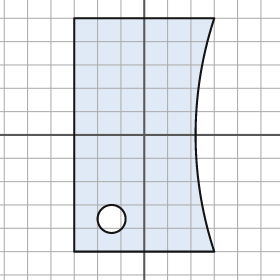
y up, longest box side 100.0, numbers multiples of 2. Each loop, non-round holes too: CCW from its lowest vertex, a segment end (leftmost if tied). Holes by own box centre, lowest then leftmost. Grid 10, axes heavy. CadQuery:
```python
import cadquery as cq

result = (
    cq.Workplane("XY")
    .moveTo(-30.0, -50.0)
    .lineTo(30.0, -50.0)
    .threePointArc((22.0, 0.0), (30.0, 50.0))
    .lineTo(-30.0, 50.0)
    .close()
    .moveTo(-14.0, -36.0)
    .circle(6.0)
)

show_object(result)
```